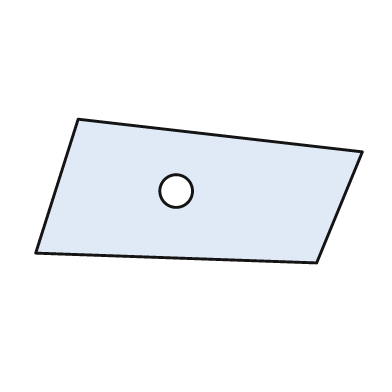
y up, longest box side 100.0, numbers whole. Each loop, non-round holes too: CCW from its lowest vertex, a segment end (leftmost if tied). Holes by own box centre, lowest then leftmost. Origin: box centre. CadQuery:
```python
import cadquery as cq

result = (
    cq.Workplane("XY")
    .moveTo(36.0, -22.0)
    .lineTo(50.0, 12.0)
    .lineTo(-37.0, 22.0)
    .lineTo(-50.0, -19.0)
    .close()
    .moveTo(-7.0, 0.0)
    .circle(5.0)
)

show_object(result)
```